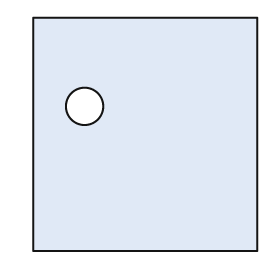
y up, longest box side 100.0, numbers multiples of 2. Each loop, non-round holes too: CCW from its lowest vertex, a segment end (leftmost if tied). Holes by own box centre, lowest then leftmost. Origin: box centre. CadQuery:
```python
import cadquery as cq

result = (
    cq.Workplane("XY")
    .moveTo(-48.0, -50.0)
    .lineTo(48.0, -50.0)
    .lineTo(48.0, 50.0)
    .lineTo(-48.0, 50.0)
    .close()
    .moveTo(-26.0, 12.0)
    .circle(8.0)
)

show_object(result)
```